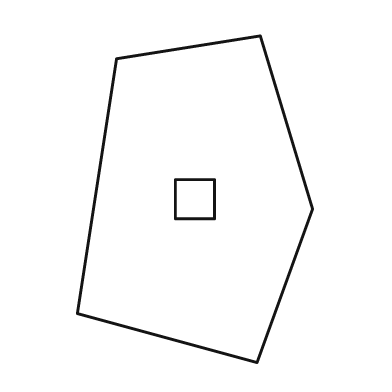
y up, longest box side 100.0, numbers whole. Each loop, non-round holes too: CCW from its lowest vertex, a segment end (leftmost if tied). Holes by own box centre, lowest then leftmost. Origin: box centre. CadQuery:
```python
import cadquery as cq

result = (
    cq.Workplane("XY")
    .moveTo(19.0, -50.0)
    .lineTo(36.0, -3.0)
    .lineTo(20.0, 50.0)
    .lineTo(-24.0, 43.0)
    .lineTo(-36.0, -35.0)
    .close()
    .moveTo(-6.0, -6.0)
    .lineTo(6.0, -6.0)
    .lineTo(6.0, 6.0)
    .lineTo(-6.0, 6.0)
    .close()
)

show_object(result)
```